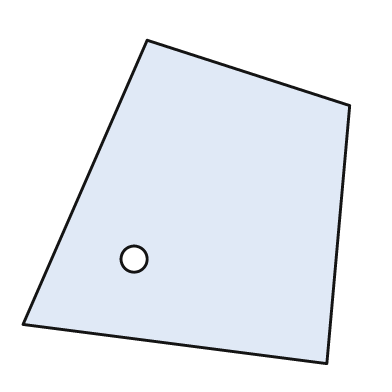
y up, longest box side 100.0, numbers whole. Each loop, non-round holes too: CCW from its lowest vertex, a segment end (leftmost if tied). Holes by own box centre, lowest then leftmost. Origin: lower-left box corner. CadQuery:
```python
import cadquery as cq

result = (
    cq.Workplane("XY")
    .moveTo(93.0, 0.0)
    .lineTo(100.0, 79.0)
    .lineTo(38.0, 99.0)
    .lineTo(0.0, 12.0)
    .close()
    .moveTo(34.0, 32.0)
    .circle(4.0)
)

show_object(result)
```